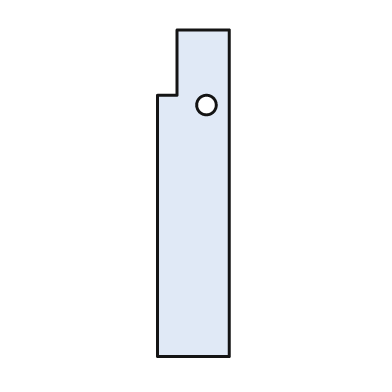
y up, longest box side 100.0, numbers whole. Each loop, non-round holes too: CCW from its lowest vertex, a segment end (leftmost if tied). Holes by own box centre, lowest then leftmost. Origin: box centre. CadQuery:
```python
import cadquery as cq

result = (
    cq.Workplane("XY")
    .moveTo(-11.0, -50.0)
    .lineTo(11.0, -50.0)
    .lineTo(11.0, 50.0)
    .lineTo(-5.0, 50.0)
    .lineTo(-5.0, 30.0)
    .lineTo(-11.0, 30.0)
    .close()
    .moveTo(4.0, 27.0)
    .circle(3.0)
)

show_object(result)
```